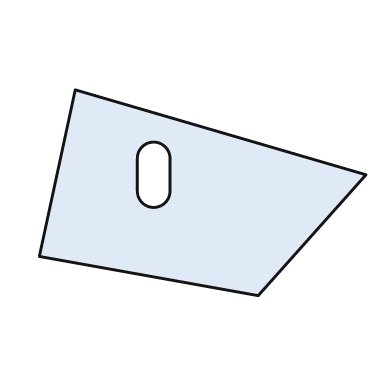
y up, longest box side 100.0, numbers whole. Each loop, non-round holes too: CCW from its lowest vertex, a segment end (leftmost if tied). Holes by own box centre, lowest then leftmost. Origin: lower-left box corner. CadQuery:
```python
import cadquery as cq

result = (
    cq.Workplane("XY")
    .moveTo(67.0, 0.0)
    .lineTo(100.0, 37.0)
    .lineTo(11.0, 63.0)
    .lineTo(0.0, 12.0)
    .close()
    .moveTo(30.0, 32.0)
    .threePointArc((35.0, 27.0), (40.0, 32.0))
    .lineTo(40.0, 42.0)
    .threePointArc((35.0, 47.0), (30.0, 42.0))
    .close()
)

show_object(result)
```